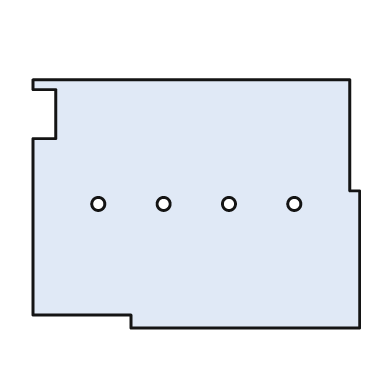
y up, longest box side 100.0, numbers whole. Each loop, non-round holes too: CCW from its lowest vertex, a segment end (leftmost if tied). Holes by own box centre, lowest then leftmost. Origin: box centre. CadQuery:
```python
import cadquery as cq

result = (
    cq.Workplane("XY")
    .moveTo(-20.0, -38.0)
    .lineTo(50.0, -38.0)
    .lineTo(50.0, 4.0)
    .lineTo(47.0, 4.0)
    .lineTo(47.0, 38.0)
    .lineTo(-50.0, 38.0)
    .lineTo(-50.0, 35.0)
    .lineTo(-43.0, 35.0)
    .lineTo(-43.0, 20.0)
    .lineTo(-50.0, 20.0)
    .lineTo(-50.0, -34.0)
    .lineTo(-20.0, -34.0)
    .close()
    .moveTo(-30.0, 0.0)
    .circle(2.0)
    .moveTo(-10.0, 0.0)
    .circle(2.0)
    .moveTo(10.0, 0.0)
    .circle(2.0)
    .moveTo(30.0, 0.0)
    .circle(2.0)
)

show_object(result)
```